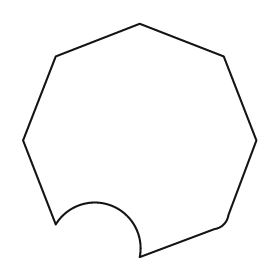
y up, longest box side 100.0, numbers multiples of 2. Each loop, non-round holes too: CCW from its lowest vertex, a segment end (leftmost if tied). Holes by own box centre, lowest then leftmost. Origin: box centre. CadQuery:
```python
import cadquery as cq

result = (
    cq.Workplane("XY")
    .moveTo(0.0, -50.0)
    .lineTo(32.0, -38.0)
    .threePointArc((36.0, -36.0), (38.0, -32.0))
    .lineTo(50.0, 0.0)
    .lineTo(36.0, 36.0)
    .lineTo(0.0, 50.0)
    .lineTo(-36.0, 36.0)
    .lineTo(-50.0, 0.0)
    .lineTo(-36.0, -36.0)
    .threePointArc((-12.0, -28.0), (0.0, -50.0))
    .close()
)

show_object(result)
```